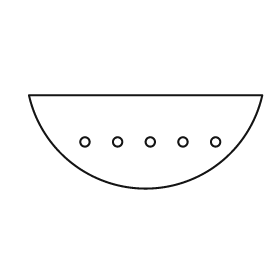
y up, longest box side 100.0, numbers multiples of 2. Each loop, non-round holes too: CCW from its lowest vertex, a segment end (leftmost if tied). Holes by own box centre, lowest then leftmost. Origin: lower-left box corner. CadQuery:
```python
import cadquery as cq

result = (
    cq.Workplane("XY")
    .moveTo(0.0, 40.0)
    .threePointArc((50.0, 0.0), (100.0, 40.0))
    .close()
    .moveTo(24.0, 20.0)
    .circle(2.0)
    .moveTo(38.0, 20.0)
    .circle(2.0)
    .moveTo(52.0, 20.0)
    .circle(2.0)
    .moveTo(66.0, 20.0)
    .circle(2.0)
    .moveTo(80.0, 20.0)
    .circle(2.0)
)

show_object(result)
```